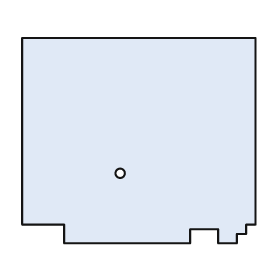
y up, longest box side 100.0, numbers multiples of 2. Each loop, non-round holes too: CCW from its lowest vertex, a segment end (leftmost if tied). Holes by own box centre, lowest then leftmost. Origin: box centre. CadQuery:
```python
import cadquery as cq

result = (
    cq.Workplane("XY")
    .moveTo(-32.0, -44.0)
    .lineTo(22.0, -44.0)
    .lineTo(22.0, -38.0)
    .lineTo(34.0, -38.0)
    .lineTo(34.0, -44.0)
    .lineTo(42.0, -44.0)
    .lineTo(42.0, -40.0)
    .lineTo(46.0, -40.0)
    .lineTo(46.0, -36.0)
    .lineTo(50.0, -36.0)
    .lineTo(50.0, 44.0)
    .lineTo(-50.0, 44.0)
    .lineTo(-50.0, -36.0)
    .lineTo(-32.0, -36.0)
    .close()
    .moveTo(-8.0, -14.0)
    .circle(2.0)
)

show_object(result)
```